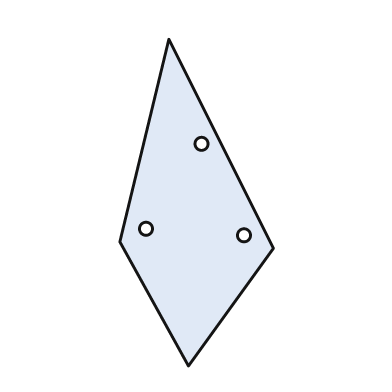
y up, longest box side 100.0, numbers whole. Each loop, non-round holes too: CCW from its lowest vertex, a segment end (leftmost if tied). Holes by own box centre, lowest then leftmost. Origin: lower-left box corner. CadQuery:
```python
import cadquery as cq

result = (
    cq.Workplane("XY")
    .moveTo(21.0, 0.0)
    .lineTo(47.0, 36.0)
    .lineTo(15.0, 100.0)
    .lineTo(0.0, 38.0)
    .close()
    .moveTo(38.0, 40.0)
    .circle(2.0)
    .moveTo(8.0, 42.0)
    .circle(2.0)
    .moveTo(25.0, 68.0)
    .circle(2.0)
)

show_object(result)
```